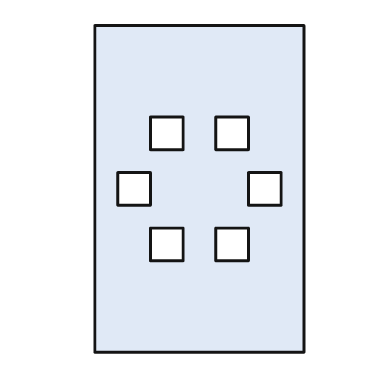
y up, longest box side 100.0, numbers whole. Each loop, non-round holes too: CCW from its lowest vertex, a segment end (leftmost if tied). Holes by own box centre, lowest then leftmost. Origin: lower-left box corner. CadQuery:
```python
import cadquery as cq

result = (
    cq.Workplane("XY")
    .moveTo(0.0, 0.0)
    .lineTo(64.0, 0.0)
    .lineTo(64.0, 100.0)
    .lineTo(0.0, 100.0)
    .close()
    .moveTo(17.0, 28.0)
    .lineTo(27.0, 28.0)
    .lineTo(27.0, 38.0)
    .lineTo(17.0, 38.0)
    .close()
    .moveTo(37.0, 28.0)
    .lineTo(47.0, 28.0)
    .lineTo(47.0, 38.0)
    .lineTo(37.0, 38.0)
    .close()
    .moveTo(7.0, 45.0)
    .lineTo(17.0, 45.0)
    .lineTo(17.0, 55.0)
    .lineTo(7.0, 55.0)
    .close()
    .moveTo(47.0, 45.0)
    .lineTo(57.0, 45.0)
    .lineTo(57.0, 55.0)
    .lineTo(47.0, 55.0)
    .close()
    .moveTo(17.0, 62.0)
    .lineTo(27.0, 62.0)
    .lineTo(27.0, 72.0)
    .lineTo(17.0, 72.0)
    .close()
    .moveTo(37.0, 62.0)
    .lineTo(47.0, 62.0)
    .lineTo(47.0, 72.0)
    .lineTo(37.0, 72.0)
    .close()
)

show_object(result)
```